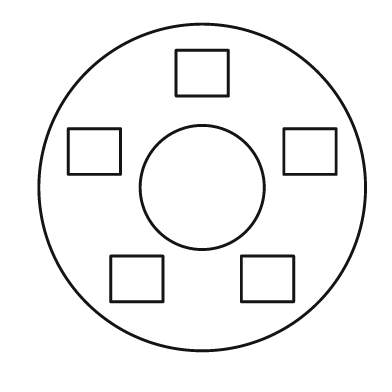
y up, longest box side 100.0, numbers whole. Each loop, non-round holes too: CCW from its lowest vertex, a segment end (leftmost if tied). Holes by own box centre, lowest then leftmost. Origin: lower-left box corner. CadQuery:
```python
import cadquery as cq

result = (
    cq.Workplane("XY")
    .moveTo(50.0, 50.0)
    .circle(50.0)
    .moveTo(22.0, 15.0)
    .lineTo(38.0, 15.0)
    .lineTo(38.0, 29.0)
    .lineTo(22.0, 29.0)
    .close()
    .moveTo(62.0, 15.0)
    .lineTo(78.0, 15.0)
    .lineTo(78.0, 29.0)
    .lineTo(62.0, 29.0)
    .close()
    .moveTo(50.0, 50.0)
    .circle(19.0)
    .moveTo(9.0, 54.0)
    .lineTo(25.0, 54.0)
    .lineTo(25.0, 68.0)
    .lineTo(9.0, 68.0)
    .close()
    .moveTo(75.0, 54.0)
    .lineTo(91.0, 54.0)
    .lineTo(91.0, 68.0)
    .lineTo(75.0, 68.0)
    .close()
    .moveTo(42.0, 78.0)
    .lineTo(58.0, 78.0)
    .lineTo(58.0, 92.0)
    .lineTo(42.0, 92.0)
    .close()
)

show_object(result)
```